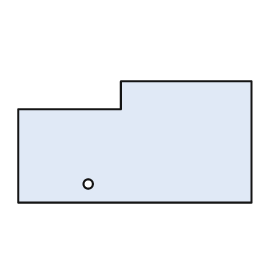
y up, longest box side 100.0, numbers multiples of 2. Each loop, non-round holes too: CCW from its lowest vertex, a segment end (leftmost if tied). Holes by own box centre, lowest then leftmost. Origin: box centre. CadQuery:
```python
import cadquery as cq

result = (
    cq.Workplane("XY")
    .moveTo(-50.0, -26.0)
    .lineTo(50.0, -26.0)
    .lineTo(50.0, 26.0)
    .lineTo(-6.0, 26.0)
    .lineTo(-6.0, 14.0)
    .lineTo(-50.0, 14.0)
    .close()
    .moveTo(-20.0, -18.0)
    .circle(2.0)
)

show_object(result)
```